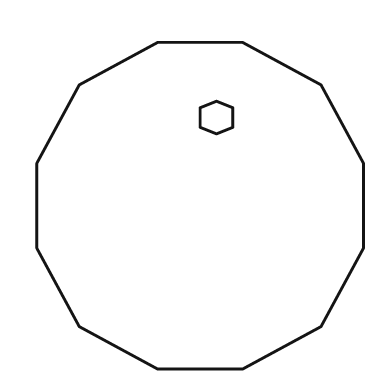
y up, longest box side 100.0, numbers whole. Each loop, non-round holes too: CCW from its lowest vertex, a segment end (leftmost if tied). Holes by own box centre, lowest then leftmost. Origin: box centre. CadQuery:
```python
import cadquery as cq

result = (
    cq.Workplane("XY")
    .moveTo(-13.0, -50.0)
    .lineTo(13.0, -50.0)
    .lineTo(37.0, -37.0)
    .lineTo(50.0, -13.0)
    .lineTo(50.0, 13.0)
    .lineTo(37.0, 37.0)
    .lineTo(13.0, 50.0)
    .lineTo(-13.0, 50.0)
    .lineTo(-37.0, 37.0)
    .lineTo(-50.0, 13.0)
    .lineTo(-50.0, -13.0)
    .lineTo(-37.0, -37.0)
    .close()
    .moveTo(5.0, 22.0)
    .lineTo(10.0, 24.0)
    .lineTo(10.0, 30.0)
    .lineTo(5.0, 32.0)
    .lineTo(0.0, 30.0)
    .lineTo(0.0, 24.0)
    .close()
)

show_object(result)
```